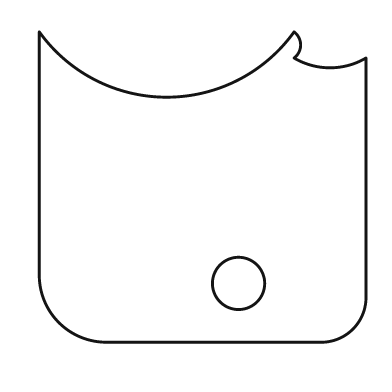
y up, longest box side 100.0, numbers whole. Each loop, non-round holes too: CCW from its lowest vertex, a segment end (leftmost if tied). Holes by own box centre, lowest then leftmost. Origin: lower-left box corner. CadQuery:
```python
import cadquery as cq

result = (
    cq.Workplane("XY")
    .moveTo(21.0, 0.0)
    .lineTo(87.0, 0.0)
    .threePointArc((96.0, 4.0), (100.0, 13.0))
    .lineTo(100.0, 87.0)
    .threePointArc((89.0, 84.0), (78.0, 87.0))
    .threePointArc((80.0, 91.0), (78.0, 95.0))
    .threePointArc((39.0, 75.0), (0.0, 95.0))
    .lineTo(0.0, 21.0)
    .threePointArc((6.0, 6.0), (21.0, 0.0))
    .close()
    .moveTo(61.0, 18.0)
    .circle(8.0)
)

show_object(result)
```